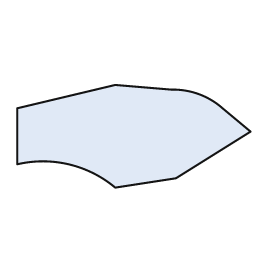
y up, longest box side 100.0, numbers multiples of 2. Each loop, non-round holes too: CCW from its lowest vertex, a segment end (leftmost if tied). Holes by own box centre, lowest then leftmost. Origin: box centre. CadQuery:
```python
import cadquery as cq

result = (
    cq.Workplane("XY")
    .moveTo(-8.0, -22.0)
    .lineTo(18.0, -18.0)
    .lineTo(50.0, 2.0)
    .lineTo(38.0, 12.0)
    .threePointArc((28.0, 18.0), (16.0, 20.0))
    .lineTo(-8.0, 22.0)
    .lineTo(-50.0, 12.0)
    .lineTo(-50.0, -12.0)
    .threePointArc((-28.0, -12.0), (-8.0, -22.0))
    .close()
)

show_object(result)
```